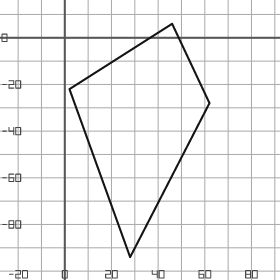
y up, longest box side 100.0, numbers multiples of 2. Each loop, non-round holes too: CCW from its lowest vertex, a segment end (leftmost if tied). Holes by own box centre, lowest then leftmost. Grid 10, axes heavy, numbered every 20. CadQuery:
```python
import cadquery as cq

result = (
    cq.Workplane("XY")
    .moveTo(28.0, -94.0)
    .lineTo(62.0, -28.0)
    .lineTo(46.0, 6.0)
    .lineTo(2.0, -22.0)
    .close()
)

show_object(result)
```